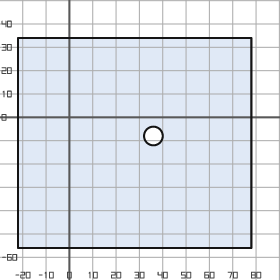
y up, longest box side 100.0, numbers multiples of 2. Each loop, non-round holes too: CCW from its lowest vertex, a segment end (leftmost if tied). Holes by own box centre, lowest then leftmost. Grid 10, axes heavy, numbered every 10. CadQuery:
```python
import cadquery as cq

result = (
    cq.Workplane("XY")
    .moveTo(-22.0, -56.0)
    .lineTo(78.0, -56.0)
    .lineTo(78.0, 34.0)
    .lineTo(-22.0, 34.0)
    .close()
    .moveTo(36.0, -8.0)
    .circle(4.0)
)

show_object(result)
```